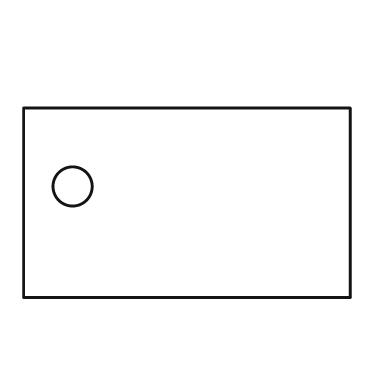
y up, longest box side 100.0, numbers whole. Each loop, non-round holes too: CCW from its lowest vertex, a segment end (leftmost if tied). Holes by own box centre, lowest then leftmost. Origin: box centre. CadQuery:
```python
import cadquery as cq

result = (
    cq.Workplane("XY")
    .moveTo(-50.0, -29.0)
    .lineTo(50.0, -29.0)
    .lineTo(50.0, 29.0)
    .lineTo(-50.0, 29.0)
    .close()
    .moveTo(-35.0, 5.0)
    .circle(6.0)
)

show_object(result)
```